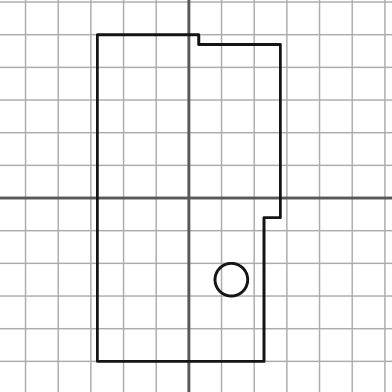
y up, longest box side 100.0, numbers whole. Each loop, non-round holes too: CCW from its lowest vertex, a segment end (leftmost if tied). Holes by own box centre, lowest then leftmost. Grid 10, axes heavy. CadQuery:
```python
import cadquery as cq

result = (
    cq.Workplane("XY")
    .moveTo(-28.0, -50.0)
    .lineTo(23.0, -50.0)
    .lineTo(23.0, -6.0)
    .lineTo(28.0, -6.0)
    .lineTo(28.0, 47.0)
    .lineTo(3.0, 47.0)
    .lineTo(3.0, 50.0)
    .lineTo(-28.0, 50.0)
    .close()
    .moveTo(13.0, -25.0)
    .circle(5.0)
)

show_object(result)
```